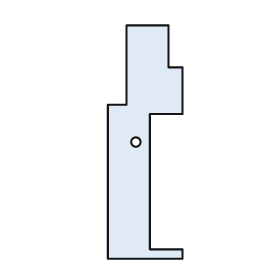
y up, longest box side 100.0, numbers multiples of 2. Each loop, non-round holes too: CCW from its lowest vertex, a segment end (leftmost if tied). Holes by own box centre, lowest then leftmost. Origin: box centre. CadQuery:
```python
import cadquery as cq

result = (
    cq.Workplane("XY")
    .moveTo(-16.0, -50.0)
    .lineTo(16.0, -50.0)
    .lineTo(16.0, -46.0)
    .lineTo(2.0, -46.0)
    .lineTo(2.0, 12.0)
    .lineTo(16.0, 12.0)
    .lineTo(16.0, 32.0)
    .lineTo(10.0, 32.0)
    .lineTo(10.0, 50.0)
    .lineTo(-8.0, 50.0)
    .lineTo(-8.0, 16.0)
    .lineTo(-16.0, 16.0)
    .close()
    .moveTo(-4.0, 0.0)
    .circle(2.0)
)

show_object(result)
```